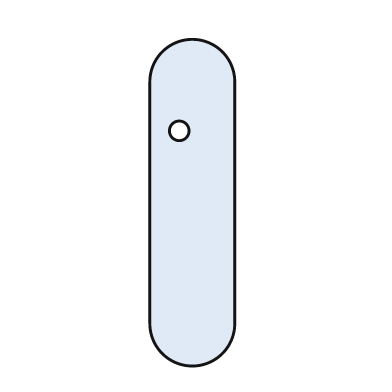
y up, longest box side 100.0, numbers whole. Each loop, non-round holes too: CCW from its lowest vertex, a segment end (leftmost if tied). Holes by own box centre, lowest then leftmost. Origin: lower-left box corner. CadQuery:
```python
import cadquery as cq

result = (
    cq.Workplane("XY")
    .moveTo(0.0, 13.0)
    .threePointArc((13.0, 0.0), (26.0, 13.0))
    .lineTo(26.0, 87.0)
    .threePointArc((13.0, 100.0), (0.0, 87.0))
    .close()
    .moveTo(9.0, 72.0)
    .circle(3.0)
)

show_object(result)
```